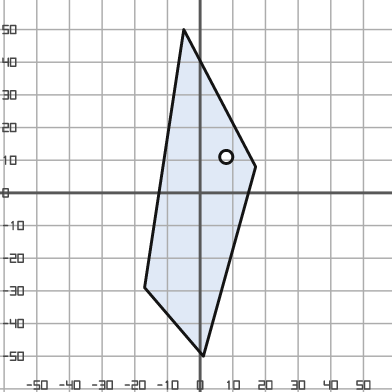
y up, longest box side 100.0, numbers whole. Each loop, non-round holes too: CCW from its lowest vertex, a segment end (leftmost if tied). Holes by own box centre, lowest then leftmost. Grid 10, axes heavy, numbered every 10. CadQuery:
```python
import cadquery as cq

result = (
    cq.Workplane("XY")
    .moveTo(1.0, -50.0)
    .lineTo(17.0, 8.0)
    .lineTo(-5.0, 50.0)
    .lineTo(-17.0, -29.0)
    .close()
    .moveTo(8.0, 11.0)
    .circle(2.0)
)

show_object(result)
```